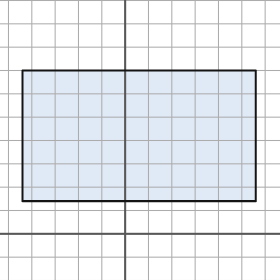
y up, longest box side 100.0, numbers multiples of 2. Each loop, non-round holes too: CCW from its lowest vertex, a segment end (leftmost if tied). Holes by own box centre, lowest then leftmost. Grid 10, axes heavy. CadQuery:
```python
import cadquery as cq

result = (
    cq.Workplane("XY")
    .moveTo(-44.0, 14.0)
    .lineTo(56.0, 14.0)
    .lineTo(56.0, 70.0)
    .lineTo(-44.0, 70.0)
    .close()
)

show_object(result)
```